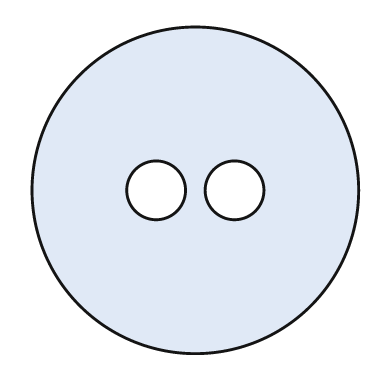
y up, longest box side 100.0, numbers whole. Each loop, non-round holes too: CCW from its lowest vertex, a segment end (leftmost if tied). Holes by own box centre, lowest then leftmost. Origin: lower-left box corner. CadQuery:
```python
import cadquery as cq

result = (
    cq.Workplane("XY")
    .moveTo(50.0, 50.0)
    .circle(50.0)
    .moveTo(38.0, 50.0)
    .circle(9.0)
    .moveTo(62.0, 50.0)
    .circle(9.0)
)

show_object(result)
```